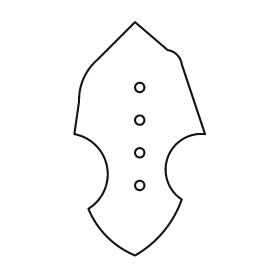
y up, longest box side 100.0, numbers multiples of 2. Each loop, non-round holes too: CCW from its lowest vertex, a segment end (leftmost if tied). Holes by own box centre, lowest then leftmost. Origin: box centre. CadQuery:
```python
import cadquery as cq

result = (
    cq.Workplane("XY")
    .moveTo(-2.0, -50.0)
    .threePointArc((10.0, -40.0), (18.0, -26.0))
    .threePointArc((12.0, -8.0), (28.0, 2.0))
    .lineTo(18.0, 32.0)
    .threePointArc((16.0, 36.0), (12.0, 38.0))
    .lineTo(-2.0, 50.0)
    .lineTo(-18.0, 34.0)
    .threePointArc((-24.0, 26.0), (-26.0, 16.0))
    .lineTo(-28.0, 2.0)
    .threePointArc((-14.0, -12.0), (-22.0, -30.0))
    .threePointArc((-14.0, -42.0), (-2.0, -50.0))
    .close()
    .moveTo(0.0, -20.0)
    .circle(2.0)
    .moveTo(0.0, -6.0)
    .circle(2.0)
    .moveTo(0.0, 8.0)
    .circle(2.0)
    .moveTo(0.0, 22.0)
    .circle(2.0)
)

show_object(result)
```